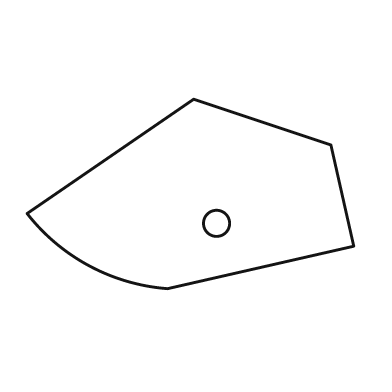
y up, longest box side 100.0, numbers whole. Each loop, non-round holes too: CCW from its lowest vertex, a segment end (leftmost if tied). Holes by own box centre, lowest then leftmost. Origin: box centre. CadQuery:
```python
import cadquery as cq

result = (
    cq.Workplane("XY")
    .moveTo(-7.0, -29.0)
    .lineTo(50.0, -16.0)
    .lineTo(43.0, 15.0)
    .lineTo(1.0, 29.0)
    .lineTo(-50.0, -6.0)
    .threePointArc((-31.0, -22.0), (-7.0, -29.0))
    .close()
    .moveTo(8.0, -9.0)
    .circle(4.0)
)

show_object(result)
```